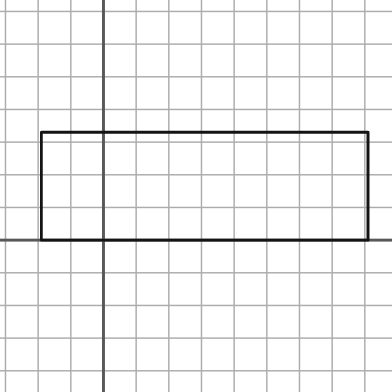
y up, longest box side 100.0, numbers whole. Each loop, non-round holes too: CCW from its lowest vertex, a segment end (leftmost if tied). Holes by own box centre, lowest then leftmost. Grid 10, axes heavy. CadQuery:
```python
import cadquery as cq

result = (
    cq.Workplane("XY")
    .moveTo(-19.0, 0.0)
    .lineTo(81.0, 0.0)
    .lineTo(81.0, 33.0)
    .lineTo(-19.0, 33.0)
    .close()
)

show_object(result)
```